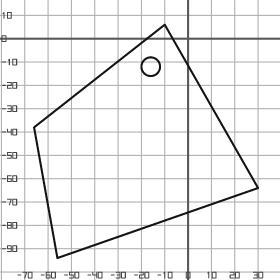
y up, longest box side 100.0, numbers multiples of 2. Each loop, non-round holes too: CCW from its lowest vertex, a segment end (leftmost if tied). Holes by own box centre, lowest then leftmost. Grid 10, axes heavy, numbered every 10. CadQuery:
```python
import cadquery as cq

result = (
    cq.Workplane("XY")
    .moveTo(-56.0, -94.0)
    .lineTo(30.0, -64.0)
    .lineTo(-10.0, 6.0)
    .lineTo(-66.0, -38.0)
    .close()
    .moveTo(-16.0, -12.0)
    .circle(4.0)
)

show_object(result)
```